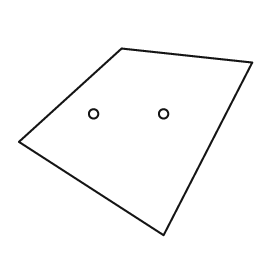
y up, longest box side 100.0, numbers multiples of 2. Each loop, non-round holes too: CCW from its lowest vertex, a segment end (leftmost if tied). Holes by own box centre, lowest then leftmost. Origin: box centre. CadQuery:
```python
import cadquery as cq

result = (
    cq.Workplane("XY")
    .moveTo(12.0, -40.0)
    .lineTo(50.0, 34.0)
    .lineTo(-6.0, 40.0)
    .lineTo(-50.0, 0.0)
    .close()
    .moveTo(-18.0, 12.0)
    .circle(2.0)
    .moveTo(12.0, 12.0)
    .circle(2.0)
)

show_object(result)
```